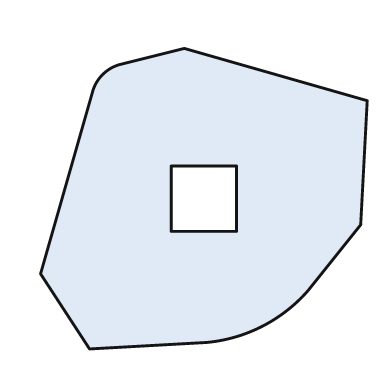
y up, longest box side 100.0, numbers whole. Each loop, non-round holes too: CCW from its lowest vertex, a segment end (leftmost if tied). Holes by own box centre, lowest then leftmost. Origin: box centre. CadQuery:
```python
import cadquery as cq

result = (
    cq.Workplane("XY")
    .moveTo(-35.0, -46.0)
    .lineTo(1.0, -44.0)
    .threePointArc((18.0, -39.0), (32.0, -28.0))
    .lineTo(48.0, -8.0)
    .lineTo(50.0, 30.0)
    .lineTo(-6.0, 46.0)
    .lineTo(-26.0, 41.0)
    .threePointArc((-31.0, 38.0), (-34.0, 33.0))
    .lineTo(-50.0, -23.0)
    .close()
    .moveTo(-10.0, -10.0)
    .lineTo(10.0, -10.0)
    .lineTo(10.0, 10.0)
    .lineTo(-10.0, 10.0)
    .close()
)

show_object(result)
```